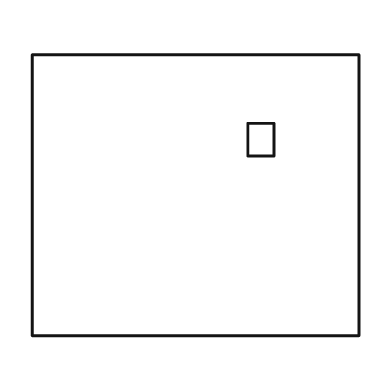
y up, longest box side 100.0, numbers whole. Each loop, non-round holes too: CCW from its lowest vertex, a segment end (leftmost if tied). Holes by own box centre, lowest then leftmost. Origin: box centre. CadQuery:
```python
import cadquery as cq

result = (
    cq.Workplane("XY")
    .moveTo(-50.0, -43.0)
    .lineTo(50.0, -43.0)
    .lineTo(50.0, 43.0)
    .lineTo(-50.0, 43.0)
    .close()
    .moveTo(16.0, 12.0)
    .lineTo(24.0, 12.0)
    .lineTo(24.0, 22.0)
    .lineTo(16.0, 22.0)
    .close()
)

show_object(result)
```